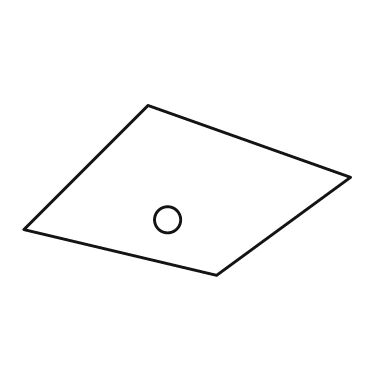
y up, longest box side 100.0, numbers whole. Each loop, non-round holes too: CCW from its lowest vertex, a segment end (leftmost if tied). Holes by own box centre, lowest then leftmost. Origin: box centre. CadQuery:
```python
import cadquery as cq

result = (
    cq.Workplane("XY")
    .moveTo(9.0, -26.0)
    .lineTo(50.0, 4.0)
    .lineTo(-12.0, 26.0)
    .lineTo(-50.0, -12.0)
    .close()
    .moveTo(-6.0, -9.0)
    .circle(4.0)
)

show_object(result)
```